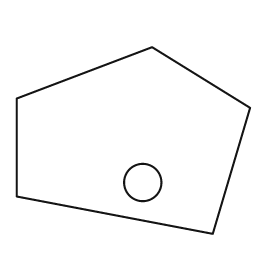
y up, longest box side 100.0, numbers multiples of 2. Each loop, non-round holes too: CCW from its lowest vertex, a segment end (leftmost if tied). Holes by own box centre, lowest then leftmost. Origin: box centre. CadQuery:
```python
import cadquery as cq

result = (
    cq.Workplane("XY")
    .moveTo(34.0, -40.0)
    .lineTo(50.0, 14.0)
    .lineTo(8.0, 40.0)
    .lineTo(-50.0, 18.0)
    .lineTo(-50.0, -24.0)
    .close()
    .moveTo(4.0, -18.0)
    .circle(8.0)
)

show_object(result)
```